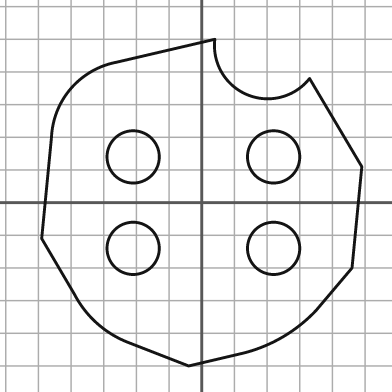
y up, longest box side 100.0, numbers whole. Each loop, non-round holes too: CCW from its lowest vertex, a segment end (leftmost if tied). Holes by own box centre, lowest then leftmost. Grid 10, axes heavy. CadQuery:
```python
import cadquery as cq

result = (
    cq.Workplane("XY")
    .moveTo(-4.0, -50.0)
    .lineTo(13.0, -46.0)
    .threePointArc((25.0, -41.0), (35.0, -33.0))
    .lineTo(46.0, -20.0)
    .lineTo(49.0, 11.0)
    .lineTo(33.0, 38.0)
    .threePointArc((14.0, 33.0), (4.0, 50.0))
    .lineTo(-26.0, 43.0)
    .threePointArc((-40.0, 35.0), (-46.0, 20.0))
    .lineTo(-49.0, -11.0)
    .lineTo(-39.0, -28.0)
    .threePointArc((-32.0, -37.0), (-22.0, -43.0))
    .close()
    .moveTo(-21.0, -14.0)
    .circle(8.0)
    .moveTo(22.0, -14.0)
    .circle(8.0)
    .moveTo(-21.0, 14.0)
    .circle(8.0)
    .moveTo(22.0, 14.0)
    .circle(8.0)
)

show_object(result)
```